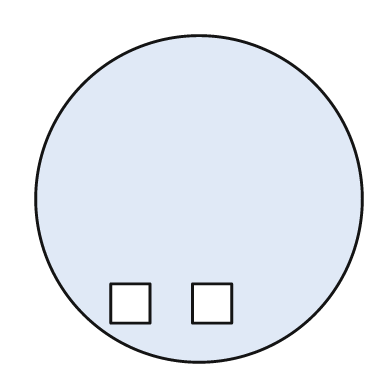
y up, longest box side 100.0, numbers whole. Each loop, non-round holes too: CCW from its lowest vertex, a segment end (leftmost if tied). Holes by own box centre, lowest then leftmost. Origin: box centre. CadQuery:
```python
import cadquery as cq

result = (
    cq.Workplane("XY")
    .moveTo(0.0, 0.0)
    .circle(50.0)
    .moveTo(-27.0, -38.0)
    .lineTo(-15.0, -38.0)
    .lineTo(-15.0, -26.0)
    .lineTo(-27.0, -26.0)
    .close()
    .moveTo(-2.0, -38.0)
    .lineTo(10.0, -38.0)
    .lineTo(10.0, -26.0)
    .lineTo(-2.0, -26.0)
    .close()
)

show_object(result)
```